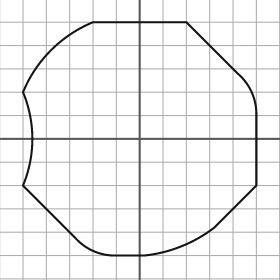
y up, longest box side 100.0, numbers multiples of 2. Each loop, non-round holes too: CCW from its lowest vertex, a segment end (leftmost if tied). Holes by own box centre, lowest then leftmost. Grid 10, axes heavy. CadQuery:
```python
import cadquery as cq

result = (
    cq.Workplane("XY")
    .moveTo(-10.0, -50.0)
    .lineTo(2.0, -50.0)
    .threePointArc((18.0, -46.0), (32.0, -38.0))
    .lineTo(50.0, -20.0)
    .lineTo(50.0, 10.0)
    .threePointArc((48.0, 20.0), (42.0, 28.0))
    .lineTo(20.0, 50.0)
    .lineTo(-20.0, 50.0)
    .threePointArc((-38.0, 38.0), (-50.0, 20.0))
    .threePointArc((-46.0, 0.0), (-50.0, -20.0))
    .lineTo(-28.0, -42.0)
    .threePointArc((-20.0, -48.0), (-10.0, -50.0))
    .close()
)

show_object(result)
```